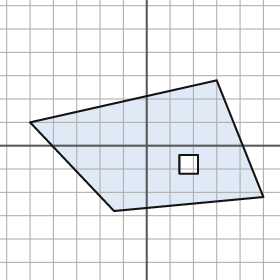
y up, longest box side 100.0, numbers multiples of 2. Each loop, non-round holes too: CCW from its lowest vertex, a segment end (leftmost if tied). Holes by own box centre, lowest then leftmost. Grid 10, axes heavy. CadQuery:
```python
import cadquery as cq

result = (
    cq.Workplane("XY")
    .moveTo(-14.0, -28.0)
    .lineTo(50.0, -22.0)
    .lineTo(30.0, 28.0)
    .lineTo(-50.0, 10.0)
    .close()
    .moveTo(14.0, -12.0)
    .lineTo(22.0, -12.0)
    .lineTo(22.0, -4.0)
    .lineTo(14.0, -4.0)
    .close()
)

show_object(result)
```